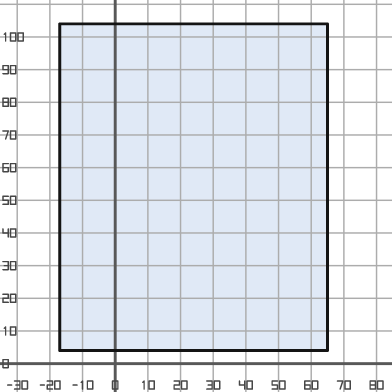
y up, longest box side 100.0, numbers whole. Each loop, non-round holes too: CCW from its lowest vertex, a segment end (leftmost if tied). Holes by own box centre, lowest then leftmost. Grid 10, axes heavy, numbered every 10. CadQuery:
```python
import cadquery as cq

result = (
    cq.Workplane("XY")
    .moveTo(-17.0, 4.0)
    .lineTo(65.0, 4.0)
    .lineTo(65.0, 104.0)
    .lineTo(-17.0, 104.0)
    .close()
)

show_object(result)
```